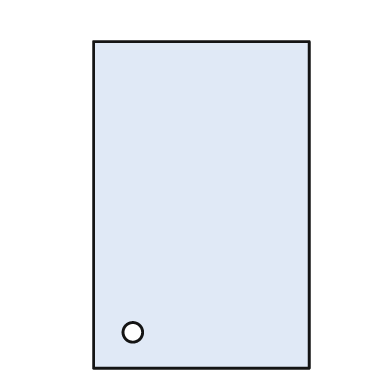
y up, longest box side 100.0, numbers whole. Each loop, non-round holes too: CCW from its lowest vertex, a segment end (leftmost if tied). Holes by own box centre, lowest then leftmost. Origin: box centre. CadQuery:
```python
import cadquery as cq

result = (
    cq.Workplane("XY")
    .moveTo(-33.0, -50.0)
    .lineTo(33.0, -50.0)
    .lineTo(33.0, 50.0)
    .lineTo(-33.0, 50.0)
    .close()
    .moveTo(-21.0, -39.0)
    .circle(3.0)
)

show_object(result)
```